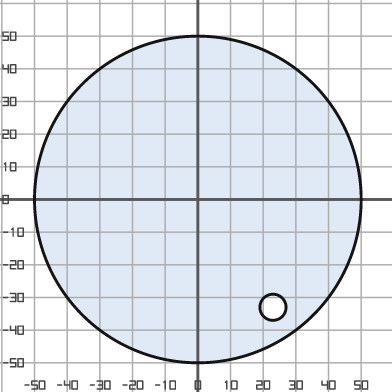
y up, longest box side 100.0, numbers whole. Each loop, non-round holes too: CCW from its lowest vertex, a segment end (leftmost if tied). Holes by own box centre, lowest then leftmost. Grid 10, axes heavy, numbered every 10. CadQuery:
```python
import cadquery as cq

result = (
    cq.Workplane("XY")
    .moveTo(0.0, 0.0)
    .circle(50.0)
    .moveTo(23.0, -33.0)
    .circle(4.0)
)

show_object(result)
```